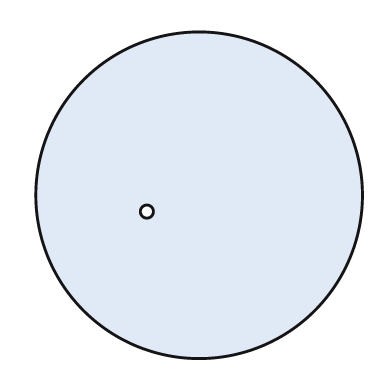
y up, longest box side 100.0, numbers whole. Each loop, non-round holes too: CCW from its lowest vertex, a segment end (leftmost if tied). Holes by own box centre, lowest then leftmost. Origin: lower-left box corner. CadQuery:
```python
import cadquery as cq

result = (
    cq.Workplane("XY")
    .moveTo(50.0, 50.0)
    .circle(50.0)
    .moveTo(34.0, 45.0)
    .circle(2.0)
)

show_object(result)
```